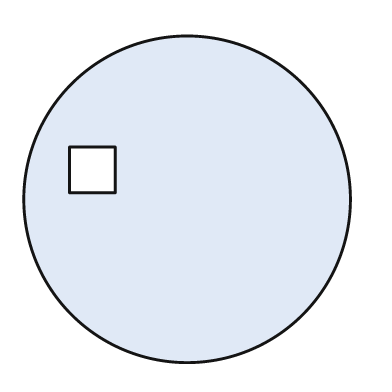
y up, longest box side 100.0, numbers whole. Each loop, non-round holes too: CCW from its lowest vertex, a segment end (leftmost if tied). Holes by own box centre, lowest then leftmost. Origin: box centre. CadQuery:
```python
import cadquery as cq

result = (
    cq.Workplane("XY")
    .moveTo(0.0, 0.0)
    .circle(50.0)
    .moveTo(-36.0, 2.0)
    .lineTo(-22.0, 2.0)
    .lineTo(-22.0, 16.0)
    .lineTo(-36.0, 16.0)
    .close()
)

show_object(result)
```